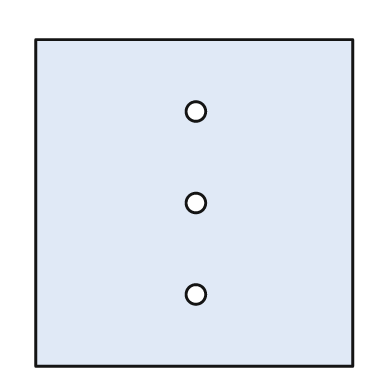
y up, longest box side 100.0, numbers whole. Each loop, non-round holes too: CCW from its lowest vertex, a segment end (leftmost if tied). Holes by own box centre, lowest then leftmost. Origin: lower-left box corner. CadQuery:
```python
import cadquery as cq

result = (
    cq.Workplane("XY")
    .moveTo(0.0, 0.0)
    .lineTo(97.0, 0.0)
    .lineTo(97.0, 100.0)
    .lineTo(0.0, 100.0)
    .close()
    .moveTo(49.0, 22.0)
    .circle(3.0)
    .moveTo(49.0, 50.0)
    .circle(3.0)
    .moveTo(49.0, 78.0)
    .circle(3.0)
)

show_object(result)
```